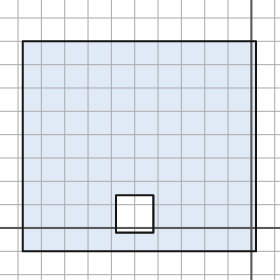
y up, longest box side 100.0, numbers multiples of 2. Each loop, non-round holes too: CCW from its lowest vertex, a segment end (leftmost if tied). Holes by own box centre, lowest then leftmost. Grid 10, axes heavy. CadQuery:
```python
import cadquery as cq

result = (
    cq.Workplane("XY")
    .moveTo(-98.0, -10.0)
    .lineTo(2.0, -10.0)
    .lineTo(2.0, 80.0)
    .lineTo(-98.0, 80.0)
    .close()
    .moveTo(-58.0, -2.0)
    .lineTo(-42.0, -2.0)
    .lineTo(-42.0, 14.0)
    .lineTo(-58.0, 14.0)
    .close()
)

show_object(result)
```